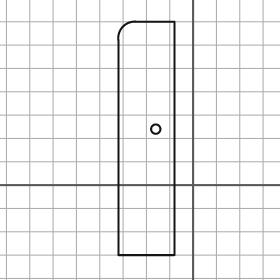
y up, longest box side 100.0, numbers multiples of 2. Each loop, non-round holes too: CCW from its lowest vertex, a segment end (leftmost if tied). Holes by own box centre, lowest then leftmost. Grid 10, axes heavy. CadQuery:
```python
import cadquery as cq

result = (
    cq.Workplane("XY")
    .moveTo(-32.0, -30.0)
    .lineTo(-8.0, -30.0)
    .lineTo(-8.0, 70.0)
    .lineTo(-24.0, 70.0)
    .threePointArc((-30.0, 68.0), (-32.0, 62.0))
    .close()
    .moveTo(-16.0, 24.0)
    .circle(2.0)
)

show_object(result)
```